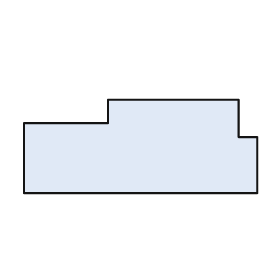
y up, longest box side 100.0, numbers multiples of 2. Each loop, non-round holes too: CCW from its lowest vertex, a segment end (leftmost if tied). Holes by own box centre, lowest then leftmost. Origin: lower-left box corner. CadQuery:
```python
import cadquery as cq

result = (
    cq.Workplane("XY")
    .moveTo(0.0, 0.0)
    .lineTo(100.0, 0.0)
    .lineTo(100.0, 24.0)
    .lineTo(92.0, 24.0)
    .lineTo(92.0, 40.0)
    .lineTo(36.0, 40.0)
    .lineTo(36.0, 30.0)
    .lineTo(0.0, 30.0)
    .close()
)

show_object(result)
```